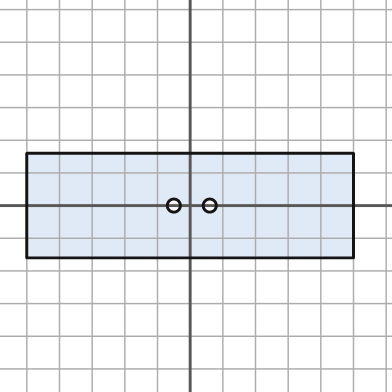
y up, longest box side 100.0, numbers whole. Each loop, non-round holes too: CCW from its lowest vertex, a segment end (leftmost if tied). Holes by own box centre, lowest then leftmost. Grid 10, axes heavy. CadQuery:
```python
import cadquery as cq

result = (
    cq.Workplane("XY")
    .moveTo(-50.0, -16.0)
    .lineTo(50.0, -16.0)
    .lineTo(50.0, 16.0)
    .lineTo(-50.0, 16.0)
    .close()
    .moveTo(-5.0, 0.0)
    .circle(2.0)
    .moveTo(6.0, 0.0)
    .circle(2.0)
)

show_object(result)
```